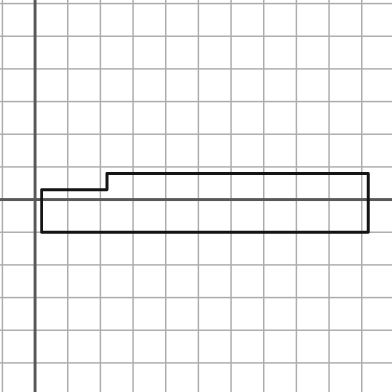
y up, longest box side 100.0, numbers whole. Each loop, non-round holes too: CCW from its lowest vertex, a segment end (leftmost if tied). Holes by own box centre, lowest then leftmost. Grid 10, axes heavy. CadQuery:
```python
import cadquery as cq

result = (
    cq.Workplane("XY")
    .moveTo(2.0, -10.0)
    .lineTo(102.0, -10.0)
    .lineTo(102.0, 8.0)
    .lineTo(22.0, 8.0)
    .lineTo(22.0, 3.0)
    .lineTo(2.0, 3.0)
    .close()
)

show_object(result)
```